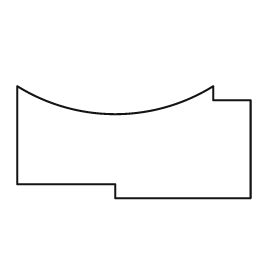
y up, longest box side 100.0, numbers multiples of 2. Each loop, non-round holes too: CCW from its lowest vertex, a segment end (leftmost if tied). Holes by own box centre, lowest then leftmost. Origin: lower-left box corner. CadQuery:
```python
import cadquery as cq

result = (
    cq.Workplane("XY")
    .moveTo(42.0, 0.0)
    .lineTo(100.0, 0.0)
    .lineTo(100.0, 42.0)
    .lineTo(84.0, 42.0)
    .lineTo(84.0, 48.0)
    .threePointArc((42.0, 36.0), (0.0, 48.0))
    .lineTo(0.0, 6.0)
    .lineTo(42.0, 6.0)
    .close()
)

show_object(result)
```